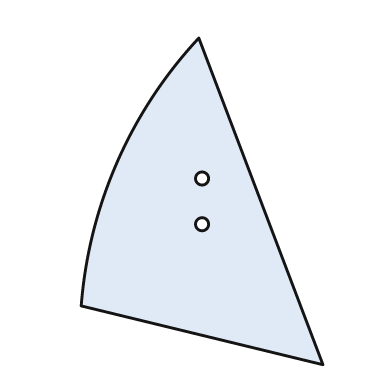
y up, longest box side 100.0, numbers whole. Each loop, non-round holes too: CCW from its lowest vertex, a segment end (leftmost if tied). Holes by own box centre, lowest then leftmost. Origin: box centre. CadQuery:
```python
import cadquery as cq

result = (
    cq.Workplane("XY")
    .moveTo(37.0, -50.0)
    .lineTo(-1.0, 50.0)
    .threePointArc((-26.0, 12.0), (-37.0, -32.0))
    .close()
    .moveTo(0.0, -7.0)
    .circle(2.0)
    .moveTo(0.0, 7.0)
    .circle(2.0)
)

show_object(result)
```